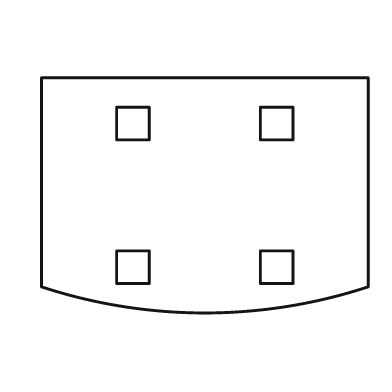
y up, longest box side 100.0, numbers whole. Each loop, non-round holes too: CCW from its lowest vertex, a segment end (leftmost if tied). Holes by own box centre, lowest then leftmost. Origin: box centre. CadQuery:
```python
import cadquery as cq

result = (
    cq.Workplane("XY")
    .moveTo(-50.0, -28.0)
    .threePointArc((0.0, -36.0), (50.0, -28.0))
    .lineTo(50.0, 36.0)
    .lineTo(-50.0, 36.0)
    .close()
    .moveTo(-27.0, -27.0)
    .lineTo(-17.0, -27.0)
    .lineTo(-17.0, -17.0)
    .lineTo(-27.0, -17.0)
    .close()
    .moveTo(17.0, -27.0)
    .lineTo(27.0, -27.0)
    .lineTo(27.0, -17.0)
    .lineTo(17.0, -17.0)
    .close()
    .moveTo(-27.0, 17.0)
    .lineTo(-17.0, 17.0)
    .lineTo(-17.0, 27.0)
    .lineTo(-27.0, 27.0)
    .close()
    .moveTo(17.0, 17.0)
    .lineTo(27.0, 17.0)
    .lineTo(27.0, 27.0)
    .lineTo(17.0, 27.0)
    .close()
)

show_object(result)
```